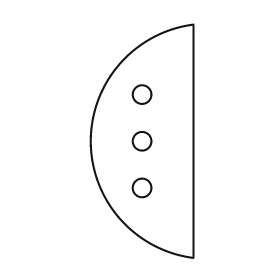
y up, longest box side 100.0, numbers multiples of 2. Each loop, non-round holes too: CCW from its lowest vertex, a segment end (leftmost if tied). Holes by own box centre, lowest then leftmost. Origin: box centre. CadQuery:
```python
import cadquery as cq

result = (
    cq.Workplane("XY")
    .moveTo(22.0, -50.0)
    .lineTo(22.0, 50.0)
    .threePointArc((-22.0, 0.0), (22.0, -50.0))
    .close()
    .moveTo(0.0, -20.0)
    .circle(4.0)
    .moveTo(0.0, 0.0)
    .circle(4.0)
    .moveTo(0.0, 20.0)
    .circle(4.0)
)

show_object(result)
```